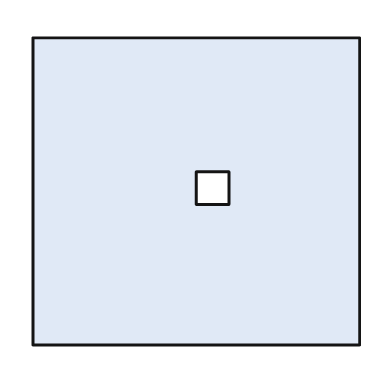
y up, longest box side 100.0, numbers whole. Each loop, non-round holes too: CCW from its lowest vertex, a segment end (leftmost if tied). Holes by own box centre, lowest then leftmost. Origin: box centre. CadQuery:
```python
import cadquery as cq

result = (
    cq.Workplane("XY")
    .moveTo(-50.0, -47.0)
    .lineTo(50.0, -47.0)
    .lineTo(50.0, 47.0)
    .lineTo(-50.0, 47.0)
    .close()
    .moveTo(0.0, -4.0)
    .lineTo(10.0, -4.0)
    .lineTo(10.0, 6.0)
    .lineTo(0.0, 6.0)
    .close()
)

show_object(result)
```